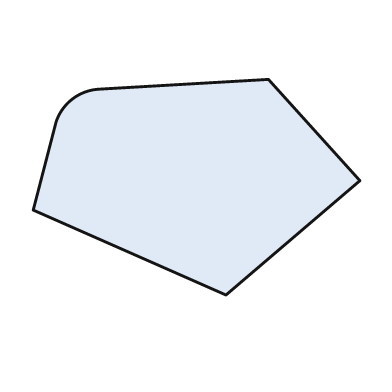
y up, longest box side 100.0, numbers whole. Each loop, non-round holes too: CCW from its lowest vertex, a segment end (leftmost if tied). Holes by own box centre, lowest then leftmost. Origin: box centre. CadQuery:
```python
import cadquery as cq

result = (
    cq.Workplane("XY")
    .moveTo(9.0, -33.0)
    .lineTo(50.0, 2.0)
    .lineTo(22.0, 33.0)
    .lineTo(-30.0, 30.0)
    .threePointArc((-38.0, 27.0), (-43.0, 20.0))
    .lineTo(-50.0, -7.0)
    .close()
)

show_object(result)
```